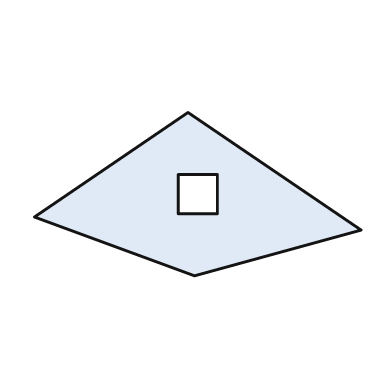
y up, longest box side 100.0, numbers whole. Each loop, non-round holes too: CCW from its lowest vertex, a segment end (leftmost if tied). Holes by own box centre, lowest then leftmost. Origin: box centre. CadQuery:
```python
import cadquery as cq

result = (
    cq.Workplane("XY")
    .moveTo(-1.0, -25.0)
    .lineTo(50.0, -11.0)
    .lineTo(-3.0, 25.0)
    .lineTo(-50.0, -7.0)
    .close()
    .moveTo(-6.0, -6.0)
    .lineTo(6.0, -6.0)
    .lineTo(6.0, 6.0)
    .lineTo(-6.0, 6.0)
    .close()
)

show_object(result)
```